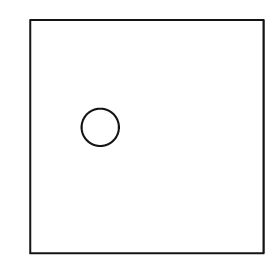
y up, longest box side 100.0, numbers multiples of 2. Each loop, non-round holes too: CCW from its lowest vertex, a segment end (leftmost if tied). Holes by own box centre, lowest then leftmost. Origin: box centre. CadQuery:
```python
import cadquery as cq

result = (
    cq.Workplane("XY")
    .moveTo(-50.0, -50.0)
    .lineTo(50.0, -50.0)
    .lineTo(50.0, 50.0)
    .lineTo(-50.0, 50.0)
    .close()
    .moveTo(-20.0, 4.0)
    .circle(8.0)
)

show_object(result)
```